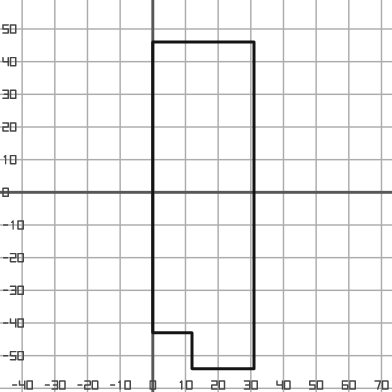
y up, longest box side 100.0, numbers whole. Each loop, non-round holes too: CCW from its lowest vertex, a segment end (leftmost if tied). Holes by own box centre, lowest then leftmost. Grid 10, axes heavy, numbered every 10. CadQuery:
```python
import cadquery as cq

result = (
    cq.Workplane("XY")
    .moveTo(12.0, -54.0)
    .lineTo(31.0, -54.0)
    .lineTo(31.0, 46.0)
    .lineTo(0.0, 46.0)
    .lineTo(0.0, -43.0)
    .lineTo(12.0, -43.0)
    .close()
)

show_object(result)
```